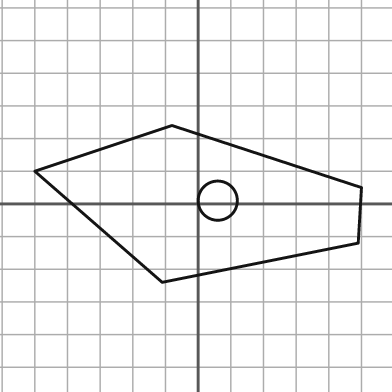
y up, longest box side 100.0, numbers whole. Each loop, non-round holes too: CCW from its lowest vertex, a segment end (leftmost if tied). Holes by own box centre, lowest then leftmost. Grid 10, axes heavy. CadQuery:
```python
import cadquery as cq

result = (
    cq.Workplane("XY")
    .moveTo(-11.0, -24.0)
    .lineTo(49.0, -12.0)
    .lineTo(50.0, 5.0)
    .lineTo(-8.0, 24.0)
    .lineTo(-50.0, 10.0)
    .close()
    .moveTo(6.0, 1.0)
    .circle(6.0)
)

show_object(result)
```